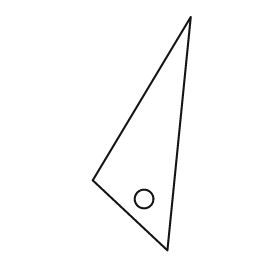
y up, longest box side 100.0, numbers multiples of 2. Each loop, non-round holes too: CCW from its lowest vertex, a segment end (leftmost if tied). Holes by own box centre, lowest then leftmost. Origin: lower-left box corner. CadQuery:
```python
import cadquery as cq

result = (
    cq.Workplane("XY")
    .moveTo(32.0, 0.0)
    .lineTo(42.0, 100.0)
    .lineTo(0.0, 30.0)
    .close()
    .moveTo(22.0, 22.0)
    .circle(4.0)
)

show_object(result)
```